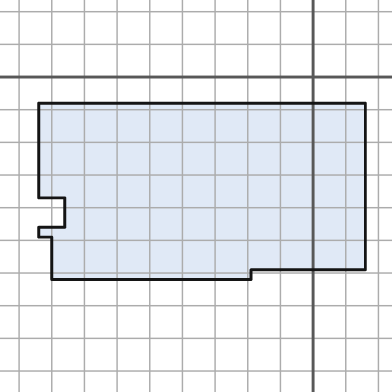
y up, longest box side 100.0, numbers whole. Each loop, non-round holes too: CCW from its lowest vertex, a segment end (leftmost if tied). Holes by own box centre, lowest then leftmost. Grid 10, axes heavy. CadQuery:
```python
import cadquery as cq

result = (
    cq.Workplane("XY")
    .moveTo(-80.0, -62.0)
    .lineTo(-19.0, -62.0)
    .lineTo(-19.0, -59.0)
    .lineTo(16.0, -59.0)
    .lineTo(16.0, -8.0)
    .lineTo(-84.0, -8.0)
    .lineTo(-84.0, -37.0)
    .lineTo(-76.0, -37.0)
    .lineTo(-76.0, -46.0)
    .lineTo(-84.0, -46.0)
    .lineTo(-84.0, -49.0)
    .lineTo(-80.0, -49.0)
    .close()
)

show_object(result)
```